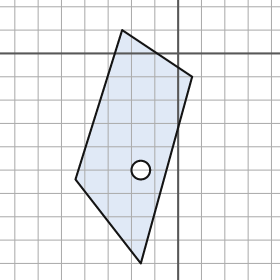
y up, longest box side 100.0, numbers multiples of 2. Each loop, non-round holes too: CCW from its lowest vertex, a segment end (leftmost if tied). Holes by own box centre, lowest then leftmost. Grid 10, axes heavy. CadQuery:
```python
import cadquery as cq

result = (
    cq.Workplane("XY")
    .moveTo(-16.0, -90.0)
    .lineTo(6.0, -10.0)
    .lineTo(-24.0, 10.0)
    .lineTo(-44.0, -54.0)
    .close()
    .moveTo(-16.0, -50.0)
    .circle(4.0)
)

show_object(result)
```